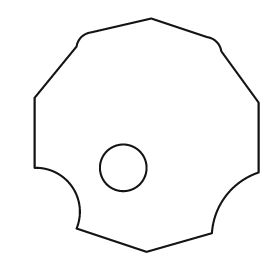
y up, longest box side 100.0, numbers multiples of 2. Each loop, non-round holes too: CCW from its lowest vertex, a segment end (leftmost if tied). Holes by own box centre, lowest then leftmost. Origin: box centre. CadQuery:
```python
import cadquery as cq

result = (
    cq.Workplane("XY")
    .moveTo(0.0, -50.0)
    .lineTo(28.0, -42.0)
    .threePointArc((34.0, -26.0), (48.0, -16.0))
    .lineTo(48.0, 14.0)
    .lineTo(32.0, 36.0)
    .threePointArc((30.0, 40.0), (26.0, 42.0))
    .lineTo(2.0, 50.0)
    .lineTo(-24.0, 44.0)
    .threePointArc((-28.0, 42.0), (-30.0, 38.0))
    .lineTo(-48.0, 16.0)
    .lineTo(-48.0, -14.0)
    .threePointArc((-32.0, -22.0), (-30.0, -40.0))
    .close()
    .moveTo(-10.0, -14.0)
    .circle(10.0)
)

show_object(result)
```